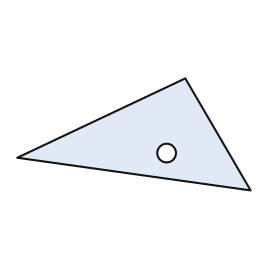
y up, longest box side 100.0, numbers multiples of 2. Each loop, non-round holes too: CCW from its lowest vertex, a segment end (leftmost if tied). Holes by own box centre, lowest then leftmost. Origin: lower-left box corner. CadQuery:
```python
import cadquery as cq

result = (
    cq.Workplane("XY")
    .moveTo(100.0, 0.0)
    .lineTo(72.0, 48.0)
    .lineTo(0.0, 14.0)
    .close()
    .moveTo(64.0, 16.0)
    .circle(4.0)
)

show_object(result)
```